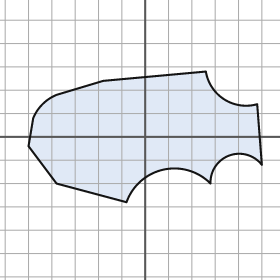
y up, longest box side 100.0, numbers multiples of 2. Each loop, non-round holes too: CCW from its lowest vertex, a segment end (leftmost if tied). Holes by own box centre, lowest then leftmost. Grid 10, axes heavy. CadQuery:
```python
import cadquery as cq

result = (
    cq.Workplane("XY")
    .moveTo(-8.0, -28.0)
    .threePointArc((8.0, -14.0), (28.0, -20.0))
    .threePointArc((36.0, -8.0), (50.0, -12.0))
    .lineTo(48.0, 14.0)
    .threePointArc((34.0, 16.0), (26.0, 28.0))
    .lineTo(-18.0, 24.0)
    .lineTo(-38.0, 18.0)
    .threePointArc((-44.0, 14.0), (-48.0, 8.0))
    .lineTo(-50.0, -4.0)
    .lineTo(-38.0, -20.0)
    .close()
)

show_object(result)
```